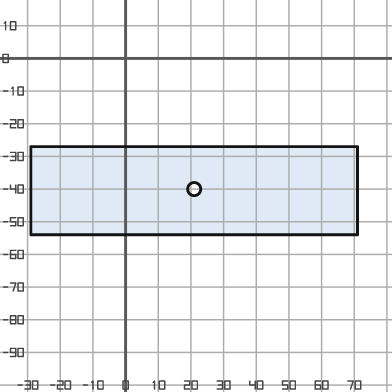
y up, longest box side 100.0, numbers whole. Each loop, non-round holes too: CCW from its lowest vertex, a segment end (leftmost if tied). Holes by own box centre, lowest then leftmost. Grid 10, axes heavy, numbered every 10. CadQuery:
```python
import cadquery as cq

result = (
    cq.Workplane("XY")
    .moveTo(-29.0, -54.0)
    .lineTo(71.0, -54.0)
    .lineTo(71.0, -27.0)
    .lineTo(-29.0, -27.0)
    .close()
    .moveTo(21.0, -40.0)
    .circle(2.0)
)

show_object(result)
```